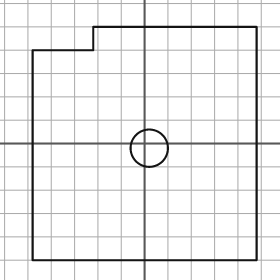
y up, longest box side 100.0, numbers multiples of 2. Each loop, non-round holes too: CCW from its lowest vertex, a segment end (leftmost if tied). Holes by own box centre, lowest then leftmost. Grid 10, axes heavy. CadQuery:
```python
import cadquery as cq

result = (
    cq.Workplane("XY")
    .moveTo(-48.0, -50.0)
    .lineTo(48.0, -50.0)
    .lineTo(48.0, 50.0)
    .lineTo(-22.0, 50.0)
    .lineTo(-22.0, 40.0)
    .lineTo(-48.0, 40.0)
    .close()
    .moveTo(2.0, -2.0)
    .circle(8.0)
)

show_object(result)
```